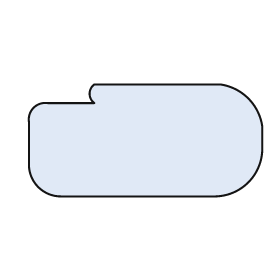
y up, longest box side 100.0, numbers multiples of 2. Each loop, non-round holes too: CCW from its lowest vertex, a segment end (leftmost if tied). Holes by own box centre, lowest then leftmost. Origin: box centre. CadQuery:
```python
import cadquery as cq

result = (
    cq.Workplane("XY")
    .moveTo(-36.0, -24.0)
    .lineTo(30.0, -24.0)
    .threePointArc((44.0, -18.0), (50.0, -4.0))
    .lineTo(50.0, 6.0)
    .threePointArc((44.0, 18.0), (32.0, 24.0))
    .lineTo(-22.0, 24.0)
    .threePointArc((-24.0, 20.0), (-22.0, 16.0))
    .lineTo(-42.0, 16.0)
    .threePointArc((-48.0, 14.0), (-50.0, 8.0))
    .lineTo(-50.0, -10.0)
    .threePointArc((-46.0, -20.0), (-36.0, -24.0))
    .close()
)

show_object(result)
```